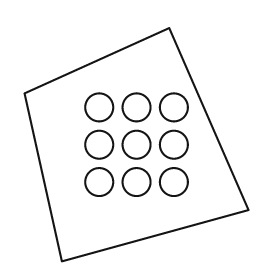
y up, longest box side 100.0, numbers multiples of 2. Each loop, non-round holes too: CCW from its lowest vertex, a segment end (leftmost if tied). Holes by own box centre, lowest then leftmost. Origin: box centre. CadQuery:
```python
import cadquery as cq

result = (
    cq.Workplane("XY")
    .moveTo(-32.0, -50.0)
    .lineTo(48.0, -28.0)
    .lineTo(14.0, 50.0)
    .lineTo(-48.0, 22.0)
    .close()
    .moveTo(-16.0, -16.0)
    .circle(6.0)
    .moveTo(0.0, -16.0)
    .circle(6.0)
    .moveTo(16.0, -16.0)
    .circle(6.0)
    .moveTo(-16.0, 0.0)
    .circle(6.0)
    .moveTo(0.0, 0.0)
    .circle(6.0)
    .moveTo(16.0, 0.0)
    .circle(6.0)
    .moveTo(-16.0, 16.0)
    .circle(6.0)
    .moveTo(0.0, 16.0)
    .circle(6.0)
    .moveTo(16.0, 16.0)
    .circle(6.0)
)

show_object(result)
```